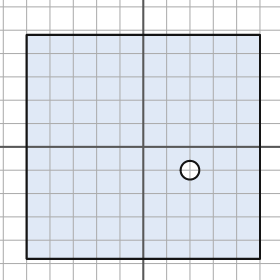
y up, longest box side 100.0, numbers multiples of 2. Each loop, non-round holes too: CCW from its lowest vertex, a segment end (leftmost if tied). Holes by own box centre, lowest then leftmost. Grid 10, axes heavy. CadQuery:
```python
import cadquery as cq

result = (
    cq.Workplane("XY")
    .moveTo(-50.0, -48.0)
    .lineTo(50.0, -48.0)
    .lineTo(50.0, 48.0)
    .lineTo(-50.0, 48.0)
    .close()
    .moveTo(20.0, -10.0)
    .circle(4.0)
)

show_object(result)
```